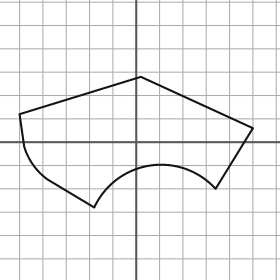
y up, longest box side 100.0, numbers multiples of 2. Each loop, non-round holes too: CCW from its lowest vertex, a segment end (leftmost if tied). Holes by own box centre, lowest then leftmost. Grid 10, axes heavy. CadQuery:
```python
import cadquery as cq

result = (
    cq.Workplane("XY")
    .moveTo(-18.0, -28.0)
    .threePointArc((6.0, -10.0), (34.0, -20.0))
    .lineTo(50.0, 6.0)
    .lineTo(2.0, 28.0)
    .lineTo(-50.0, 12.0)
    .lineTo(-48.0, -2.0)
    .threePointArc((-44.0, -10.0), (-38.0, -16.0))
    .close()
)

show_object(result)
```